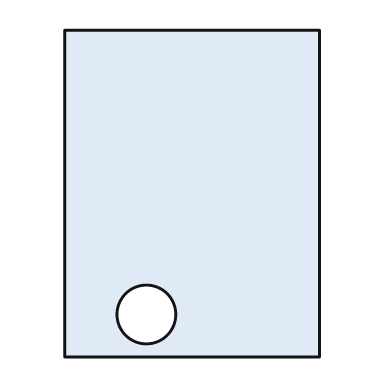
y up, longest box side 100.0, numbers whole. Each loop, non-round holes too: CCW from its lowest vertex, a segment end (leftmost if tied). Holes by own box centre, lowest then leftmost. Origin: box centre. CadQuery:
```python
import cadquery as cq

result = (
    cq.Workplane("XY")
    .moveTo(-39.0, -50.0)
    .lineTo(39.0, -50.0)
    .lineTo(39.0, 50.0)
    .lineTo(-39.0, 50.0)
    .close()
    .moveTo(-14.0, -37.0)
    .circle(9.0)
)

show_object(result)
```